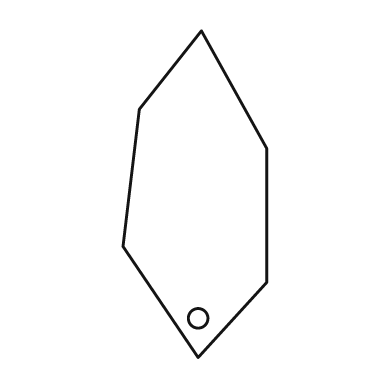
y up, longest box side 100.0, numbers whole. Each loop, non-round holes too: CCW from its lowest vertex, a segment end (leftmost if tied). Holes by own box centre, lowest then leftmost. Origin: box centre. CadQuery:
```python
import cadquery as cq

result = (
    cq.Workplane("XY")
    .moveTo(1.0, -50.0)
    .lineTo(22.0, -27.0)
    .lineTo(22.0, 14.0)
    .lineTo(2.0, 50.0)
    .lineTo(-17.0, 26.0)
    .lineTo(-22.0, -16.0)
    .close()
    .moveTo(1.0, -38.0)
    .circle(3.0)
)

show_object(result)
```